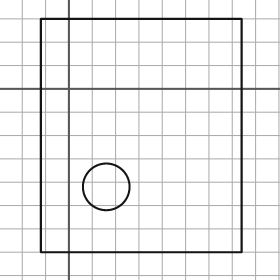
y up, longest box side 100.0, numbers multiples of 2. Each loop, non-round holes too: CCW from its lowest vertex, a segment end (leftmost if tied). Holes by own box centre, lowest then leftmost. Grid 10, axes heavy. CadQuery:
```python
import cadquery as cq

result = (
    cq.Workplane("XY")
    .moveTo(-12.0, -70.0)
    .lineTo(74.0, -70.0)
    .lineTo(74.0, 30.0)
    .lineTo(-12.0, 30.0)
    .close()
    .moveTo(16.0, -42.0)
    .circle(10.0)
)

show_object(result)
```